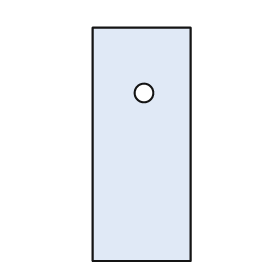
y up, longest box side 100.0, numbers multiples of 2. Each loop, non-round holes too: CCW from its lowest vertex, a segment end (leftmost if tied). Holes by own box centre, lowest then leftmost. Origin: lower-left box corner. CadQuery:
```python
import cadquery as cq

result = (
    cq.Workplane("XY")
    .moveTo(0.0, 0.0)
    .lineTo(42.0, 0.0)
    .lineTo(42.0, 100.0)
    .lineTo(0.0, 100.0)
    .close()
    .moveTo(22.0, 72.0)
    .circle(4.0)
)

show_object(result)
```